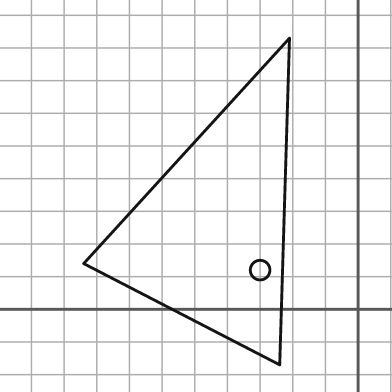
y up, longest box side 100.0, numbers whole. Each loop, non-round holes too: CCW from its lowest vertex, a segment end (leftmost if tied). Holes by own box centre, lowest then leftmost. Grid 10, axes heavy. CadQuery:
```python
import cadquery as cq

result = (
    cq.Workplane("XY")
    .moveTo(-24.0, -17.0)
    .lineTo(-21.0, 83.0)
    .lineTo(-84.0, 14.0)
    .close()
    .moveTo(-30.0, 12.0)
    .circle(3.0)
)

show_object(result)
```